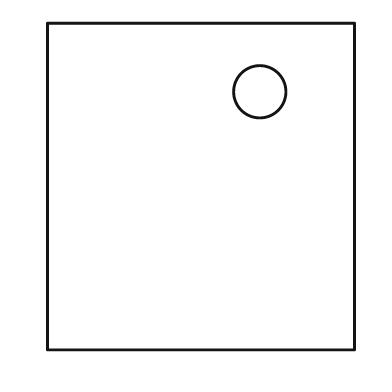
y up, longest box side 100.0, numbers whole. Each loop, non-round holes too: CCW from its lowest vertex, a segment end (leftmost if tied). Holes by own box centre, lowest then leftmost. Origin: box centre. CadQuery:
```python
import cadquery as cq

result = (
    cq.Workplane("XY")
    .moveTo(-47.0, -50.0)
    .lineTo(47.0, -50.0)
    .lineTo(47.0, 50.0)
    .lineTo(-47.0, 50.0)
    .close()
    .moveTo(18.0, 29.0)
    .circle(8.0)
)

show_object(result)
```